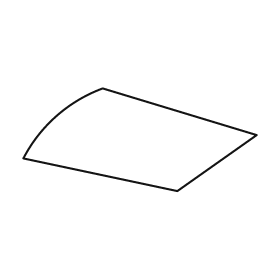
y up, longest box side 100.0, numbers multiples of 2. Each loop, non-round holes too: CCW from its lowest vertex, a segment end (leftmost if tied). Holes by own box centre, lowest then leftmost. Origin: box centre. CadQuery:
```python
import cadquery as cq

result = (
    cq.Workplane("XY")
    .moveTo(16.0, -22.0)
    .lineTo(50.0, 2.0)
    .lineTo(-16.0, 22.0)
    .threePointArc((-36.0, 10.0), (-50.0, -8.0))
    .close()
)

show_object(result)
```